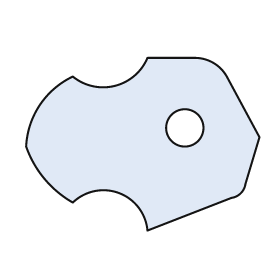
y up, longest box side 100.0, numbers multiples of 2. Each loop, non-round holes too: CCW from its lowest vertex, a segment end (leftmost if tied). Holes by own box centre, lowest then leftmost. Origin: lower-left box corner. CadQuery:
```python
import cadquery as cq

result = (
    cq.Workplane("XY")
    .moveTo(52.0, 0.0)
    .lineTo(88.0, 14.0)
    .threePointArc((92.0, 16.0), (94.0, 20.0))
    .lineTo(100.0, 40.0)
    .lineTo(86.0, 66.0)
    .threePointArc((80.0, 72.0), (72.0, 74.0))
    .lineTo(52.0, 74.0)
    .threePointArc((38.0, 62.0), (20.0, 66.0))
    .threePointArc((6.0, 54.0), (0.0, 36.0))
    .threePointArc((8.0, 22.0), (20.0, 12.0))
    .threePointArc((40.0, 16.0), (52.0, 0.0))
    .close()
    .moveTo(68.0, 44.0)
    .circle(8.0)
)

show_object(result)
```